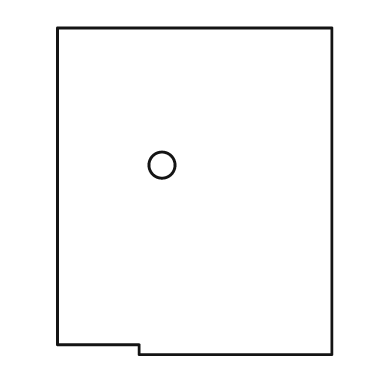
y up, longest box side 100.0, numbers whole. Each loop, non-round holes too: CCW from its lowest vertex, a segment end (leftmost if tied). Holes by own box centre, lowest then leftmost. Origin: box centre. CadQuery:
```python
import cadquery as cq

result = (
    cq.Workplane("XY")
    .moveTo(-17.0, -50.0)
    .lineTo(42.0, -50.0)
    .lineTo(42.0, 50.0)
    .lineTo(-42.0, 50.0)
    .lineTo(-42.0, -47.0)
    .lineTo(-17.0, -47.0)
    .close()
    .moveTo(-10.0, 8.0)
    .circle(4.0)
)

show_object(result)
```